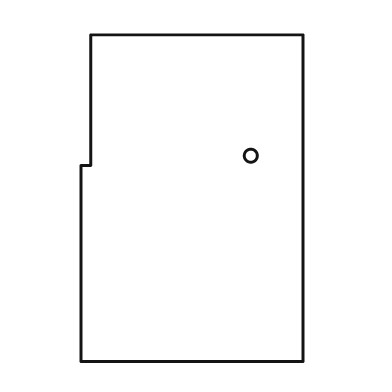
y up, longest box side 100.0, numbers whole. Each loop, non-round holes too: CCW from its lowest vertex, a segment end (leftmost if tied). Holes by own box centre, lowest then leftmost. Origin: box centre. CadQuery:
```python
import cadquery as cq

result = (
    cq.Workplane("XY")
    .moveTo(-34.0, -50.0)
    .lineTo(34.0, -50.0)
    .lineTo(34.0, 50.0)
    .lineTo(-31.0, 50.0)
    .lineTo(-31.0, 10.0)
    .lineTo(-34.0, 10.0)
    .close()
    .moveTo(18.0, 13.0)
    .circle(2.0)
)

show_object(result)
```